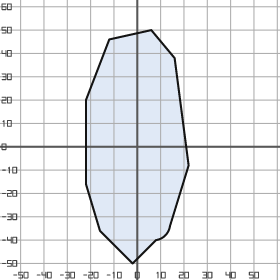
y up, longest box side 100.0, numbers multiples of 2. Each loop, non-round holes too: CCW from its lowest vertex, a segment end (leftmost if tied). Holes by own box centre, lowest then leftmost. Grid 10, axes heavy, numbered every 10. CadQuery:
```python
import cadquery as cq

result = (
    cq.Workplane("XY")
    .moveTo(-2.0, -50.0)
    .lineTo(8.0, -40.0)
    .threePointArc((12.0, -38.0), (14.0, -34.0))
    .lineTo(22.0, -8.0)
    .lineTo(16.0, 38.0)
    .lineTo(6.0, 50.0)
    .lineTo(-12.0, 46.0)
    .lineTo(-22.0, 20.0)
    .lineTo(-22.0, -16.0)
    .lineTo(-16.0, -36.0)
    .close()
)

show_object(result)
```